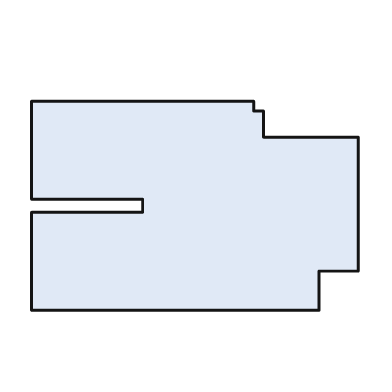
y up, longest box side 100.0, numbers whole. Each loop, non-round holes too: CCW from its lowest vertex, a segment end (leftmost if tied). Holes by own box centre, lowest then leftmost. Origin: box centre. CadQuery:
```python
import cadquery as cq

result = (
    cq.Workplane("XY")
    .moveTo(-50.0, -32.0)
    .lineTo(38.0, -32.0)
    .lineTo(38.0, -20.0)
    .lineTo(50.0, -20.0)
    .lineTo(50.0, 21.0)
    .lineTo(21.0, 21.0)
    .lineTo(21.0, 29.0)
    .lineTo(18.0, 29.0)
    .lineTo(18.0, 32.0)
    .lineTo(-50.0, 32.0)
    .lineTo(-50.0, 2.0)
    .lineTo(-16.0, 2.0)
    .lineTo(-16.0, -2.0)
    .lineTo(-50.0, -2.0)
    .close()
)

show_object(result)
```